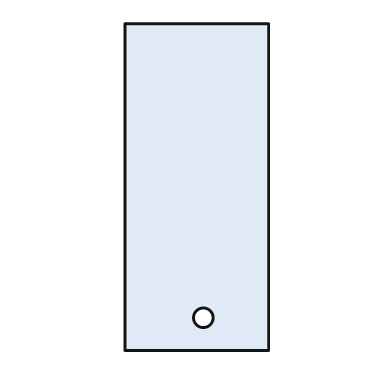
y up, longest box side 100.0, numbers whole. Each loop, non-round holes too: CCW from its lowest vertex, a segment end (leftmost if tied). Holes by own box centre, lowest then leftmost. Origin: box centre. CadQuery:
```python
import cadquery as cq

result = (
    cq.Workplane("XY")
    .moveTo(-22.0, -50.0)
    .lineTo(22.0, -50.0)
    .lineTo(22.0, 50.0)
    .lineTo(-22.0, 50.0)
    .close()
    .moveTo(2.0, -40.0)
    .circle(3.0)
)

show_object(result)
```